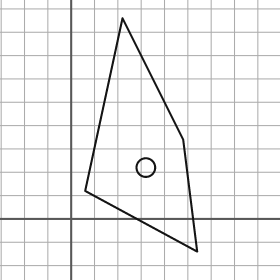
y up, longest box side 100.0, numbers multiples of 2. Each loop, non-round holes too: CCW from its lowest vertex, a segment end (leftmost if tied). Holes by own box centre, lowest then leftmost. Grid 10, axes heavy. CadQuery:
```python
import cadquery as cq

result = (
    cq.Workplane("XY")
    .moveTo(54.0, -14.0)
    .lineTo(48.0, 34.0)
    .lineTo(22.0, 86.0)
    .lineTo(6.0, 12.0)
    .close()
    .moveTo(32.0, 22.0)
    .circle(4.0)
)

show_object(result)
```